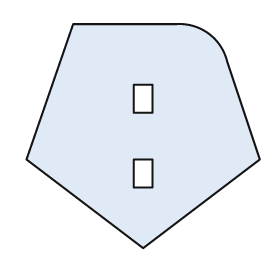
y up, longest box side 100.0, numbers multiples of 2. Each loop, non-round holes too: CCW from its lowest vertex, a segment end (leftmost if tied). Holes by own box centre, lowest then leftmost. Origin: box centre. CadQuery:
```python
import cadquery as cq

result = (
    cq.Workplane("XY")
    .moveTo(0.0, -48.0)
    .lineTo(50.0, -10.0)
    .lineTo(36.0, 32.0)
    .threePointArc((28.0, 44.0), (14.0, 48.0))
    .lineTo(-30.0, 48.0)
    .lineTo(-50.0, -10.0)
    .close()
    .moveTo(-4.0, -22.0)
    .lineTo(4.0, -22.0)
    .lineTo(4.0, -10.0)
    .lineTo(-4.0, -10.0)
    .close()
    .moveTo(-4.0, 10.0)
    .lineTo(4.0, 10.0)
    .lineTo(4.0, 22.0)
    .lineTo(-4.0, 22.0)
    .close()
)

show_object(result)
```